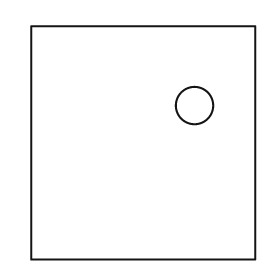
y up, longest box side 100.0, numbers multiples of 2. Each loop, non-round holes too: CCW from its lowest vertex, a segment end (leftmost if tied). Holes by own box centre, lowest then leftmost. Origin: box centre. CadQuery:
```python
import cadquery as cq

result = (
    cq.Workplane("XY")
    .moveTo(-48.0, -50.0)
    .lineTo(48.0, -50.0)
    .lineTo(48.0, 50.0)
    .lineTo(-48.0, 50.0)
    .close()
    .moveTo(22.0, 16.0)
    .circle(8.0)
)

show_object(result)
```